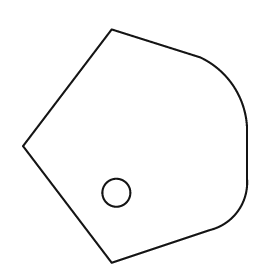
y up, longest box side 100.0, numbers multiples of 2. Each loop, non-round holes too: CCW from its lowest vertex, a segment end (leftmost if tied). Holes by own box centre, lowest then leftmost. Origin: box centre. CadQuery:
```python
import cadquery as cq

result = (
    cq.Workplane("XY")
    .moveTo(-10.0, -50.0)
    .lineTo(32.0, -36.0)
    .threePointArc((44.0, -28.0), (48.0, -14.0))
    .lineTo(48.0, 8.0)
    .threePointArc((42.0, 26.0), (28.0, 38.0))
    .lineTo(-10.0, 50.0)
    .lineTo(-48.0, 0.0)
    .close()
    .moveTo(-8.0, -20.0)
    .circle(6.0)
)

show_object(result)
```